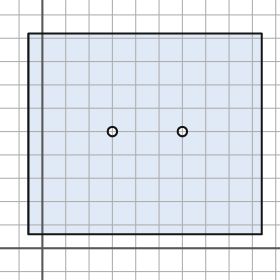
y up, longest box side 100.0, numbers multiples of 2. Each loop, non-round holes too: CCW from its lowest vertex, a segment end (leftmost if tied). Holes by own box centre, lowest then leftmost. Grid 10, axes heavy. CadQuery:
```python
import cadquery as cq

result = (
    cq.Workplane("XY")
    .moveTo(-6.0, 6.0)
    .lineTo(94.0, 6.0)
    .lineTo(94.0, 92.0)
    .lineTo(-6.0, 92.0)
    .close()
    .moveTo(30.0, 50.0)
    .circle(2.0)
    .moveTo(60.0, 50.0)
    .circle(2.0)
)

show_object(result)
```